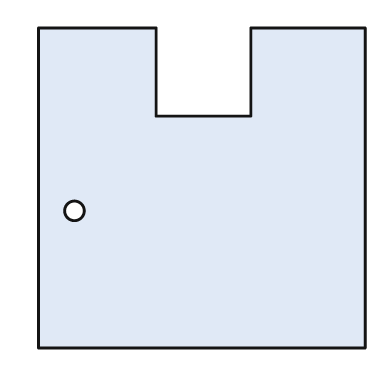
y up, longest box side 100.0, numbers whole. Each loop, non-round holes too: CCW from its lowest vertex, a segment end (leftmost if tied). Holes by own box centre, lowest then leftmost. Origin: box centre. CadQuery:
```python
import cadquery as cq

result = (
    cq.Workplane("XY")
    .moveTo(-50.0, -49.0)
    .lineTo(50.0, -49.0)
    .lineTo(50.0, 49.0)
    .lineTo(15.0, 49.0)
    .lineTo(15.0, 22.0)
    .lineTo(-14.0, 22.0)
    .lineTo(-14.0, 49.0)
    .lineTo(-50.0, 49.0)
    .close()
    .moveTo(-39.0, -7.0)
    .circle(3.0)
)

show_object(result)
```